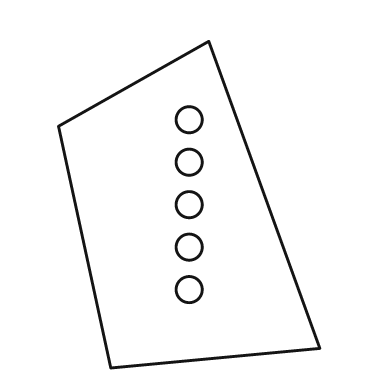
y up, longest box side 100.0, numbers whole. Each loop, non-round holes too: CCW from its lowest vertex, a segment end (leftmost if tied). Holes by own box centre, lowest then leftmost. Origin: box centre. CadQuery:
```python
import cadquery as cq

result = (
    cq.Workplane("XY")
    .moveTo(-24.0, -50.0)
    .lineTo(40.0, -44.0)
    .lineTo(6.0, 50.0)
    .lineTo(-40.0, 24.0)
    .close()
    .moveTo(0.0, -26.0)
    .circle(4.0)
    .moveTo(0.0, -13.0)
    .circle(4.0)
    .moveTo(0.0, 0.0)
    .circle(4.0)
    .moveTo(0.0, 13.0)
    .circle(4.0)
    .moveTo(0.0, 26.0)
    .circle(4.0)
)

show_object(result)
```